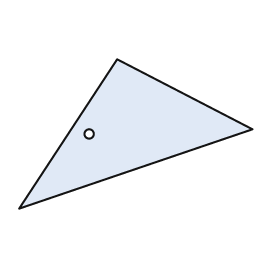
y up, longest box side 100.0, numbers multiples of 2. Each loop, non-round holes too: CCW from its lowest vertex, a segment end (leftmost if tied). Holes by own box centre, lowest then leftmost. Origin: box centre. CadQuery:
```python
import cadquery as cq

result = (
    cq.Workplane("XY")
    .moveTo(-50.0, -32.0)
    .lineTo(50.0, 2.0)
    .lineTo(-8.0, 32.0)
    .close()
    .moveTo(-20.0, 0.0)
    .circle(2.0)
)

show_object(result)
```